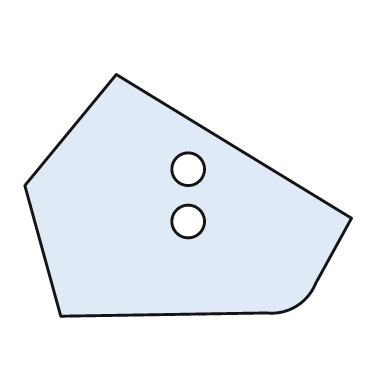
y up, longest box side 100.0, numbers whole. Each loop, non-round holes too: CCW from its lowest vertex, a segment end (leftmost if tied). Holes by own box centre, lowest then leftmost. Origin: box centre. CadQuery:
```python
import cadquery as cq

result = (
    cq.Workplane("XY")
    .moveTo(-39.0, -37.0)
    .lineTo(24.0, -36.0)
    .threePointArc((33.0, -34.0), (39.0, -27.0))
    .lineTo(50.0, -7.0)
    .lineTo(-22.0, 37.0)
    .lineTo(-50.0, 3.0)
    .close()
    .moveTo(0.0, -8.0)
    .circle(5.0)
    .moveTo(0.0, 8.0)
    .circle(5.0)
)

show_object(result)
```